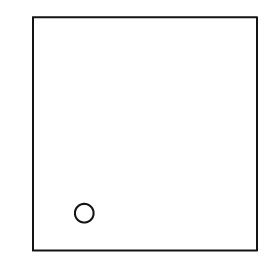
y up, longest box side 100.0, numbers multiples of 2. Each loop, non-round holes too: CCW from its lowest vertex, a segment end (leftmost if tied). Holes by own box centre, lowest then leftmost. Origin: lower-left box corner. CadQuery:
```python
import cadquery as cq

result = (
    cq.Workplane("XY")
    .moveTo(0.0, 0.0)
    .lineTo(96.0, 0.0)
    .lineTo(96.0, 100.0)
    .lineTo(0.0, 100.0)
    .close()
    .moveTo(22.0, 16.0)
    .circle(4.0)
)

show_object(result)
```